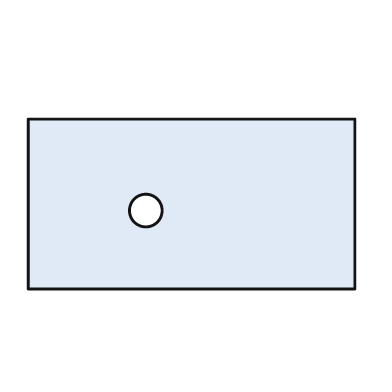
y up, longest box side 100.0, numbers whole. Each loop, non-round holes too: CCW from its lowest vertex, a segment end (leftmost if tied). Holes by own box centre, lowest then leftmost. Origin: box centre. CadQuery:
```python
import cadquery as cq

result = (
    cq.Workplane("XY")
    .moveTo(-50.0, -26.0)
    .lineTo(50.0, -26.0)
    .lineTo(50.0, 26.0)
    .lineTo(-50.0, 26.0)
    .close()
    .moveTo(-14.0, -2.0)
    .circle(5.0)
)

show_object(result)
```